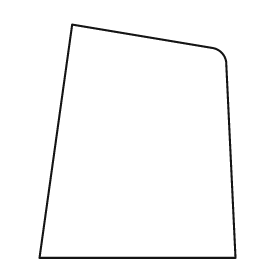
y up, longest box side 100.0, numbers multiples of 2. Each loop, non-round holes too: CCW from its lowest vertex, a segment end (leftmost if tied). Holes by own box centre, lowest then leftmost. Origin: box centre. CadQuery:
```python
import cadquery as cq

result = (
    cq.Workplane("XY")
    .moveTo(-42.0, -50.0)
    .lineTo(42.0, -50.0)
    .lineTo(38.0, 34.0)
    .threePointArc((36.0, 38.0), (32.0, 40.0))
    .lineTo(-28.0, 50.0)
    .close()
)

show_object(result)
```